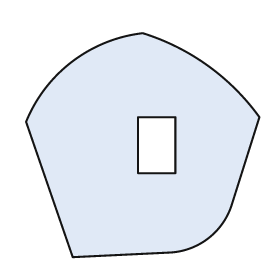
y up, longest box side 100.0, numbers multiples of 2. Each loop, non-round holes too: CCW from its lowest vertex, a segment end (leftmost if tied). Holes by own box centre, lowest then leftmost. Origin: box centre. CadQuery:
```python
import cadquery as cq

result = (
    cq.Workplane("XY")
    .moveTo(-30.0, -48.0)
    .lineTo(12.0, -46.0)
    .threePointArc((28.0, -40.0), (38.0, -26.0))
    .lineTo(50.0, 12.0)
    .threePointArc((28.0, 34.0), (0.0, 48.0))
    .threePointArc((-30.0, 36.0), (-50.0, 10.0))
    .close()
    .moveTo(-2.0, -12.0)
    .lineTo(14.0, -12.0)
    .lineTo(14.0, 12.0)
    .lineTo(-2.0, 12.0)
    .close()
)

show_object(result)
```